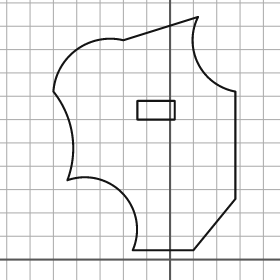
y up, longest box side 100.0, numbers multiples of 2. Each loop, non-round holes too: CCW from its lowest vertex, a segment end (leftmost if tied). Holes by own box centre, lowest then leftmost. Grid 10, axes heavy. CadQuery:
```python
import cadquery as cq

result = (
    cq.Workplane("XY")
    .moveTo(-16.0, 4.0)
    .lineTo(10.0, 4.0)
    .lineTo(28.0, 26.0)
    .lineTo(28.0, 72.0)
    .threePointArc((12.0, 84.0), (12.0, 104.0))
    .lineTo(-20.0, 94.0)
    .threePointArc((-40.0, 90.0), (-50.0, 72.0))
    .threePointArc((-42.0, 54.0), (-44.0, 34.0))
    .threePointArc((-20.0, 28.0), (-16.0, 4.0))
    .close()
    .moveTo(-14.0, 60.0)
    .lineTo(2.0, 60.0)
    .lineTo(2.0, 68.0)
    .lineTo(-14.0, 68.0)
    .close()
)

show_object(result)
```